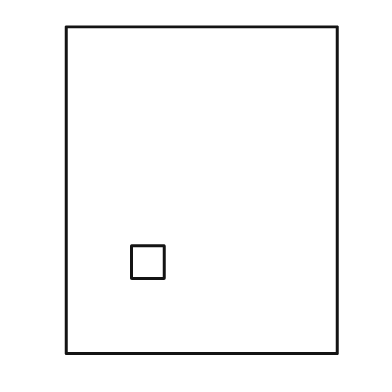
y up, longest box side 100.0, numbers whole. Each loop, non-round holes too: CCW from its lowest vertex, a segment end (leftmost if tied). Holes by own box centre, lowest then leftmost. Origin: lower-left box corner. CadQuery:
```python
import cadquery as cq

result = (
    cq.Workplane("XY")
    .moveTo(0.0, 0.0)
    .lineTo(83.0, 0.0)
    .lineTo(83.0, 100.0)
    .lineTo(0.0, 100.0)
    .close()
    .moveTo(20.0, 23.0)
    .lineTo(30.0, 23.0)
    .lineTo(30.0, 33.0)
    .lineTo(20.0, 33.0)
    .close()
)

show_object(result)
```